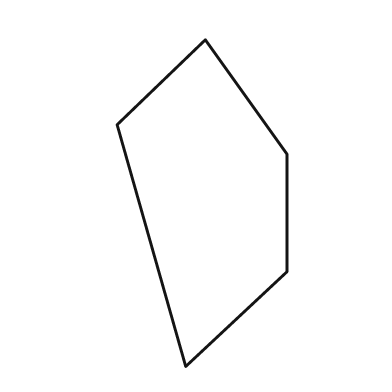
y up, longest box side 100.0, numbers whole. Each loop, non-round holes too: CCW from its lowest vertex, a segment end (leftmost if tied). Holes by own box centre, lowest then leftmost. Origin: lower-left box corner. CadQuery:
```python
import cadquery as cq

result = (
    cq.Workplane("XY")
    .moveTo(21.0, 0.0)
    .lineTo(52.0, 29.0)
    .lineTo(52.0, 65.0)
    .lineTo(27.0, 100.0)
    .lineTo(0.0, 74.0)
    .close()
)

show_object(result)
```